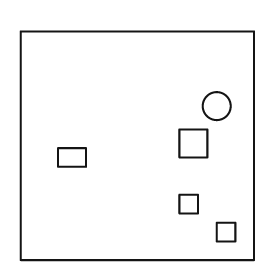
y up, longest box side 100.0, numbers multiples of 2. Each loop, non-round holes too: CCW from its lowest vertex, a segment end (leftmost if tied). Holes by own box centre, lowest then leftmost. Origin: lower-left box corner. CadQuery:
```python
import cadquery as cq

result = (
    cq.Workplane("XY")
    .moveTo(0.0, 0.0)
    .lineTo(100.0, 0.0)
    .lineTo(100.0, 98.0)
    .lineTo(0.0, 98.0)
    .close()
    .moveTo(84.0, 8.0)
    .lineTo(92.0, 8.0)
    .lineTo(92.0, 16.0)
    .lineTo(84.0, 16.0)
    .close()
    .moveTo(68.0, 20.0)
    .lineTo(76.0, 20.0)
    .lineTo(76.0, 28.0)
    .lineTo(68.0, 28.0)
    .close()
    .moveTo(16.0, 40.0)
    .lineTo(28.0, 40.0)
    .lineTo(28.0, 48.0)
    .lineTo(16.0, 48.0)
    .close()
    .moveTo(68.0, 44.0)
    .lineTo(80.0, 44.0)
    .lineTo(80.0, 56.0)
    .lineTo(68.0, 56.0)
    .close()
    .moveTo(84.0, 66.0)
    .circle(6.0)
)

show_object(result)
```